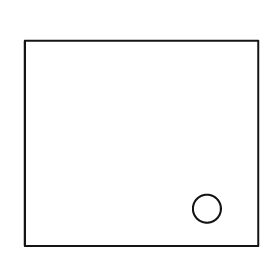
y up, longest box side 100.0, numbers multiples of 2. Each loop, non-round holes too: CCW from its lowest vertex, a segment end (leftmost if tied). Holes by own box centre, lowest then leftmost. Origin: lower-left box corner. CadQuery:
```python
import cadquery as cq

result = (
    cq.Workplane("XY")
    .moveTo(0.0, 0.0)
    .lineTo(100.0, 0.0)
    .lineTo(100.0, 88.0)
    .lineTo(0.0, 88.0)
    .close()
    .moveTo(78.0, 16.0)
    .circle(6.0)
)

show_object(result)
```